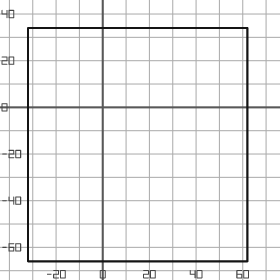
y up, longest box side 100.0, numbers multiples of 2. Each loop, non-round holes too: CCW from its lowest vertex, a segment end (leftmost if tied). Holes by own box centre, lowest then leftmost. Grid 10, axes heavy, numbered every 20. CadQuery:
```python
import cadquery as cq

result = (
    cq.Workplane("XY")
    .moveTo(-32.0, -66.0)
    .lineTo(62.0, -66.0)
    .lineTo(62.0, 34.0)
    .lineTo(-32.0, 34.0)
    .close()
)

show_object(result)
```